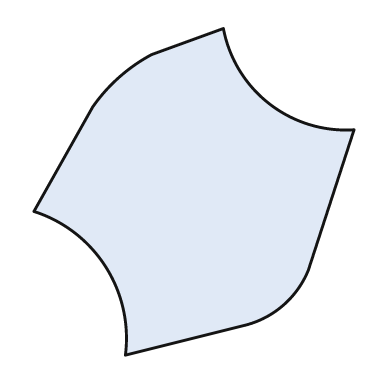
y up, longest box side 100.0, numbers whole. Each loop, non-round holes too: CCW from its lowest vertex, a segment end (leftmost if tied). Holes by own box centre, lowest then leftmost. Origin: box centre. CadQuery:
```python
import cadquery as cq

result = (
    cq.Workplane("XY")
    .moveTo(-21.0, -50.0)
    .lineTo(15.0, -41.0)
    .threePointArc((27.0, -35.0), (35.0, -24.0))
    .lineTo(49.0, 19.0)
    .threePointArc((23.0, 27.0), (9.0, 50.0))
    .lineTo(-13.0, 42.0)
    .threePointArc((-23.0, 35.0), (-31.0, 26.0))
    .lineTo(-49.0, -6.0)
    .threePointArc((-27.0, -23.0), (-21.0, -50.0))
    .close()
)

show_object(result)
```